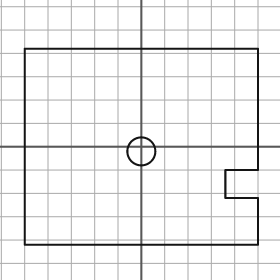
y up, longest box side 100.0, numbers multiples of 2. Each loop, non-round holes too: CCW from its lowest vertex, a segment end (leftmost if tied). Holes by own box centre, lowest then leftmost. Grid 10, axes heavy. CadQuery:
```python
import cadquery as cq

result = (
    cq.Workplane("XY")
    .moveTo(-50.0, -42.0)
    .lineTo(50.0, -42.0)
    .lineTo(50.0, -22.0)
    .lineTo(36.0, -22.0)
    .lineTo(36.0, -10.0)
    .lineTo(50.0, -10.0)
    .lineTo(50.0, 42.0)
    .lineTo(-50.0, 42.0)
    .close()
    .moveTo(0.0, -2.0)
    .circle(6.0)
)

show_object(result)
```